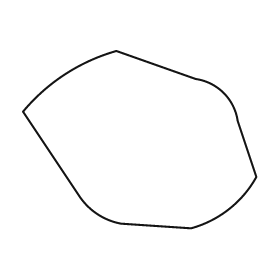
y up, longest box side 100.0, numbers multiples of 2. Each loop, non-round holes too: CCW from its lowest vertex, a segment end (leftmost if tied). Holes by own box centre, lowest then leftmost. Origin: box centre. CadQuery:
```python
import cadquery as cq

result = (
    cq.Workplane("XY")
    .moveTo(22.0, -38.0)
    .threePointArc((38.0, -30.0), (50.0, -16.0))
    .lineTo(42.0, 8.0)
    .threePointArc((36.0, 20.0), (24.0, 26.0))
    .lineTo(-10.0, 38.0)
    .threePointArc((-32.0, 28.0), (-50.0, 12.0))
    .lineTo(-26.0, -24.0)
    .threePointArc((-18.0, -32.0), (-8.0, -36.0))
    .close()
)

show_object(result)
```